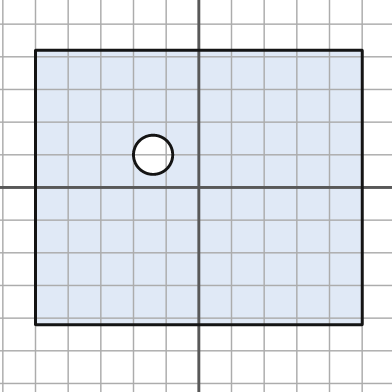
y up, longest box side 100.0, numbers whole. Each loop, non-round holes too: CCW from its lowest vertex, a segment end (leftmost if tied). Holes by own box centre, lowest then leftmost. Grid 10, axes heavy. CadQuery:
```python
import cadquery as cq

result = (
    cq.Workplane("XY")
    .moveTo(-50.0, -42.0)
    .lineTo(50.0, -42.0)
    .lineTo(50.0, 42.0)
    .lineTo(-50.0, 42.0)
    .close()
    .moveTo(-14.0, 10.0)
    .circle(6.0)
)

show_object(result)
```